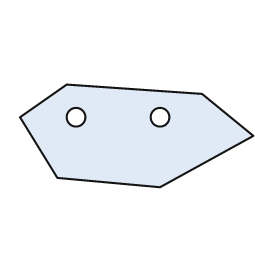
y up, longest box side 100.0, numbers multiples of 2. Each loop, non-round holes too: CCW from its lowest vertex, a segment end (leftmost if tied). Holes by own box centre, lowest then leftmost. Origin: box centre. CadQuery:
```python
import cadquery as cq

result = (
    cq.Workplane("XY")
    .moveTo(10.0, -22.0)
    .lineTo(50.0, 0.0)
    .lineTo(28.0, 18.0)
    .lineTo(-30.0, 22.0)
    .lineTo(-50.0, 8.0)
    .lineTo(-34.0, -18.0)
    .close()
    .moveTo(-26.0, 8.0)
    .circle(4.0)
    .moveTo(10.0, 8.0)
    .circle(4.0)
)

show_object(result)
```